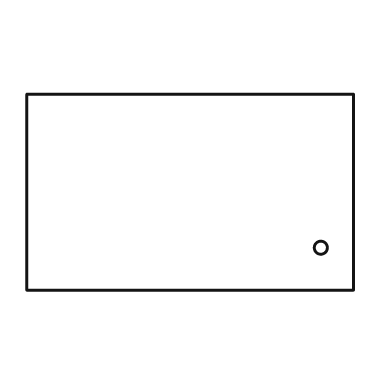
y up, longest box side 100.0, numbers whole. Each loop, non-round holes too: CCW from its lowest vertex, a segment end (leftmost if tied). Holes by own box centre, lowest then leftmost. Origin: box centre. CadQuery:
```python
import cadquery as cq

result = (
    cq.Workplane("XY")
    .moveTo(-50.0, -30.0)
    .lineTo(50.0, -30.0)
    .lineTo(50.0, 30.0)
    .lineTo(-50.0, 30.0)
    .close()
    .moveTo(40.0, -17.0)
    .circle(2.0)
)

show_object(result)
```